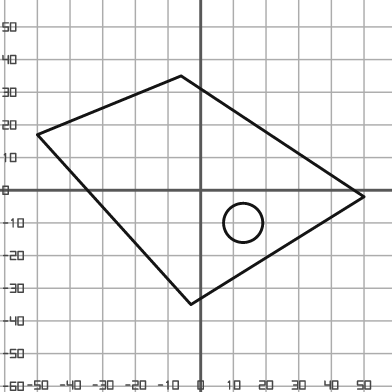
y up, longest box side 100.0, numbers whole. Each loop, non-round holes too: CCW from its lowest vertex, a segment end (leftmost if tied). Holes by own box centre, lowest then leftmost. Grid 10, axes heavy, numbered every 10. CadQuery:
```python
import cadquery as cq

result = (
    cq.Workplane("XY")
    .moveTo(-3.0, -35.0)
    .lineTo(50.0, -2.0)
    .lineTo(-6.0, 35.0)
    .lineTo(-50.0, 17.0)
    .close()
    .moveTo(13.0, -10.0)
    .circle(6.0)
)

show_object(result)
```